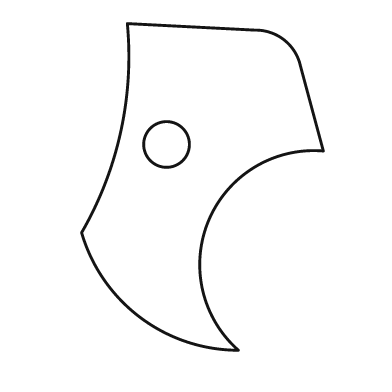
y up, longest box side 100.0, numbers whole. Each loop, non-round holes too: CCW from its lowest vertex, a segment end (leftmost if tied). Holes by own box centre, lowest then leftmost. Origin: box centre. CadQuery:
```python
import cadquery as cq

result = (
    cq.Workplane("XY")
    .moveTo(11.0, -50.0)
    .threePointArc((2.0, -10.0), (37.0, 11.0))
    .lineTo(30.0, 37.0)
    .threePointArc((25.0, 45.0), (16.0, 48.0))
    .lineTo(-23.0, 50.0)
    .threePointArc((-25.0, 17.0), (-37.0, -14.0))
    .threePointArc((-19.0, -40.0), (11.0, -50.0))
    .close()
    .moveTo(-11.0, 13.0)
    .circle(7.0)
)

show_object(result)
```